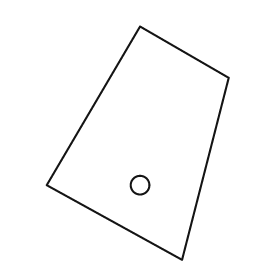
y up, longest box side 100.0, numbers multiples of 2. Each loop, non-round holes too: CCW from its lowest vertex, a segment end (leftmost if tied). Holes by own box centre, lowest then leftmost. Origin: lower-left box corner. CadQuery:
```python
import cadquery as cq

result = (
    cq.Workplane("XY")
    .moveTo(58.0, 0.0)
    .lineTo(78.0, 78.0)
    .lineTo(40.0, 100.0)
    .lineTo(0.0, 32.0)
    .close()
    .moveTo(40.0, 32.0)
    .circle(4.0)
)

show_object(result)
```